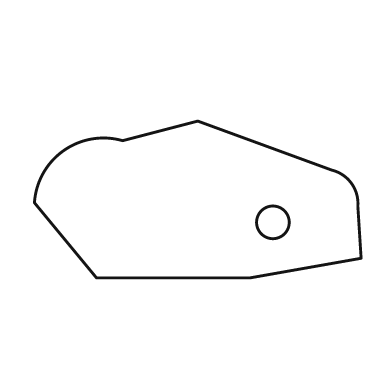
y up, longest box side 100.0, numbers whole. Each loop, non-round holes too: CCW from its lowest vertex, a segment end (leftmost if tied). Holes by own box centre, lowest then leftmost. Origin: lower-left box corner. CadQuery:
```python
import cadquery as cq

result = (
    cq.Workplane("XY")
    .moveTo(19.0, 0.0)
    .lineTo(66.0, 0.0)
    .lineTo(100.0, 6.0)
    .lineTo(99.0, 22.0)
    .threePointArc((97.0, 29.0), (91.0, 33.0))
    .lineTo(50.0, 48.0)
    .lineTo(27.0, 42.0)
    .threePointArc((9.0, 39.0), (0.0, 23.0))
    .close()
    .moveTo(73.0, 17.0)
    .circle(5.0)
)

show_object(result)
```